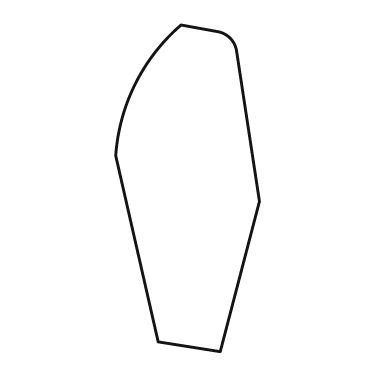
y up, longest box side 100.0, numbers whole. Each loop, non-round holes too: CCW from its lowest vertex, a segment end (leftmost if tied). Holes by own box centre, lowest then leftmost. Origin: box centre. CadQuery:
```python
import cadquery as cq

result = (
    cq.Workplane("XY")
    .moveTo(10.0, -50.0)
    .lineTo(22.0, -4.0)
    .lineTo(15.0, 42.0)
    .threePointArc((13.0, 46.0), (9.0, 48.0))
    .lineTo(-2.0, 50.0)
    .threePointArc((-16.0, 32.0), (-22.0, 10.0))
    .lineTo(-9.0, -47.0)
    .close()
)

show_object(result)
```